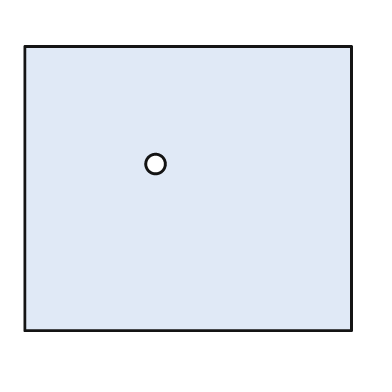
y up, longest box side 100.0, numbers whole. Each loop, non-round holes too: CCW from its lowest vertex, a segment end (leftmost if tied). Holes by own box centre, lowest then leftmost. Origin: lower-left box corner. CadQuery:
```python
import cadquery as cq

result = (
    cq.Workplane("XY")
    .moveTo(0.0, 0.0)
    .lineTo(100.0, 0.0)
    .lineTo(100.0, 87.0)
    .lineTo(0.0, 87.0)
    .close()
    .moveTo(40.0, 51.0)
    .circle(3.0)
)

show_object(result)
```